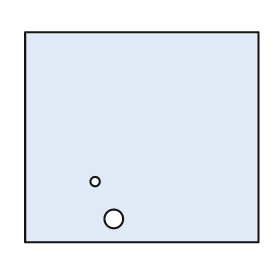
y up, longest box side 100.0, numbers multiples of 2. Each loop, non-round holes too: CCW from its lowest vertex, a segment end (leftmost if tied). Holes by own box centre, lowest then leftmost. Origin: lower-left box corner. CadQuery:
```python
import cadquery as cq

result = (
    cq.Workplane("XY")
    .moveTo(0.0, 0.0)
    .lineTo(100.0, 0.0)
    .lineTo(100.0, 90.0)
    .lineTo(0.0, 90.0)
    .close()
    .moveTo(38.0, 10.0)
    .circle(4.0)
    .moveTo(30.0, 26.0)
    .circle(2.0)
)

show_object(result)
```